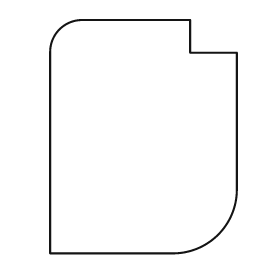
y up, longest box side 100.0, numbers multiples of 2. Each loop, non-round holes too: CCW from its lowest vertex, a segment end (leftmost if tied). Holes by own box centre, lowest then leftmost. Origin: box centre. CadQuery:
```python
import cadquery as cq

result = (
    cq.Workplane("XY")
    .moveTo(-40.0, -50.0)
    .lineTo(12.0, -50.0)
    .threePointArc((32.0, -42.0), (40.0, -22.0))
    .lineTo(40.0, 36.0)
    .lineTo(20.0, 36.0)
    .lineTo(20.0, 50.0)
    .lineTo(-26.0, 50.0)
    .threePointArc((-36.0, 46.0), (-40.0, 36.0))
    .close()
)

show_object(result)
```